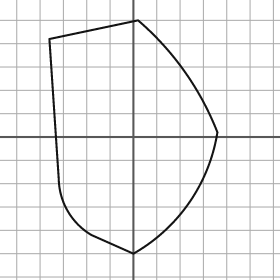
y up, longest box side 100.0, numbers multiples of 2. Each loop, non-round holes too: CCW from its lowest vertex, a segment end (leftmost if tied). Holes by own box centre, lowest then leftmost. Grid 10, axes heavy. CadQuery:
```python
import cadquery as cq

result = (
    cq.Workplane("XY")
    .moveTo(0.0, -50.0)
    .threePointArc((24.0, -28.0), (36.0, 2.0))
    .threePointArc((22.0, 28.0), (2.0, 50.0))
    .lineTo(-36.0, 42.0)
    .lineTo(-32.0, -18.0)
    .threePointArc((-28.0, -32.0), (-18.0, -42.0))
    .close()
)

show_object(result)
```